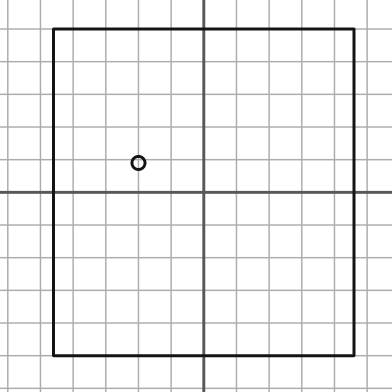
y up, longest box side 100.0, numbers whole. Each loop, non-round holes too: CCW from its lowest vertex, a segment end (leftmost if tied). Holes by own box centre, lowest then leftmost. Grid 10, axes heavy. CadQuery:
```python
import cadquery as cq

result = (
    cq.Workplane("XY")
    .moveTo(-46.0, -50.0)
    .lineTo(46.0, -50.0)
    .lineTo(46.0, 50.0)
    .lineTo(-46.0, 50.0)
    .close()
    .moveTo(-20.0, 9.0)
    .circle(2.0)
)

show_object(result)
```